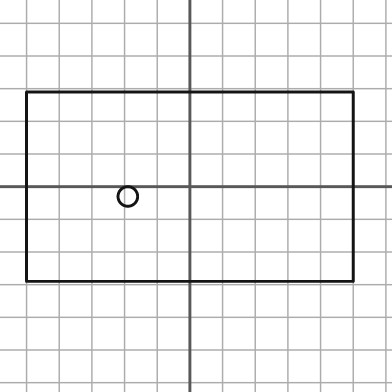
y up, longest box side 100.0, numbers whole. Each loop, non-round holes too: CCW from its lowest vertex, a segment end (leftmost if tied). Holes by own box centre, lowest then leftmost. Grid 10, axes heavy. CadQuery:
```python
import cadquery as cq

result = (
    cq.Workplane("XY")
    .moveTo(-50.0, -29.0)
    .lineTo(50.0, -29.0)
    .lineTo(50.0, 29.0)
    .lineTo(-50.0, 29.0)
    .close()
    .moveTo(-19.0, -3.0)
    .circle(3.0)
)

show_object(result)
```